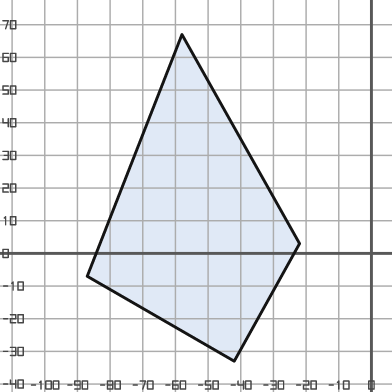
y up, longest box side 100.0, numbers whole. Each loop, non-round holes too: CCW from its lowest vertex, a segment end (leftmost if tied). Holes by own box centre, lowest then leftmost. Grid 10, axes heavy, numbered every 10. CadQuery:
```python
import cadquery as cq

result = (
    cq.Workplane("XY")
    .moveTo(-42.0, -33.0)
    .lineTo(-22.0, 3.0)
    .lineTo(-58.0, 67.0)
    .lineTo(-87.0, -7.0)
    .close()
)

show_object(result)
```